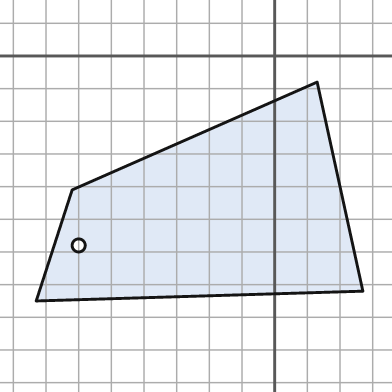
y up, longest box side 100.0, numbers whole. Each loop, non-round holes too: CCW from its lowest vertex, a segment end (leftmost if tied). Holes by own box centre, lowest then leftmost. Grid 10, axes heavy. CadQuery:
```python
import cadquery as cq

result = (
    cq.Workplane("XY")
    .moveTo(-73.0, -75.0)
    .lineTo(27.0, -72.0)
    .lineTo(13.0, -8.0)
    .lineTo(-62.0, -41.0)
    .close()
    .moveTo(-60.0, -58.0)
    .circle(2.0)
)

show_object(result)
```